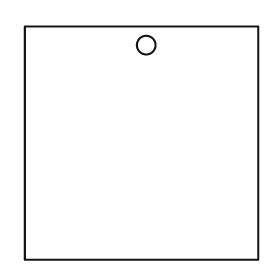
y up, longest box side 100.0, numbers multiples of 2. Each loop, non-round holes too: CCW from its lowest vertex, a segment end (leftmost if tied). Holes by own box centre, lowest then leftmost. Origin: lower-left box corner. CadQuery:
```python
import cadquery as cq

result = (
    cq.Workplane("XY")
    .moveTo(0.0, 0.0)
    .lineTo(100.0, 0.0)
    .lineTo(100.0, 100.0)
    .lineTo(0.0, 100.0)
    .close()
    .moveTo(52.0, 92.0)
    .circle(4.0)
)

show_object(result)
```